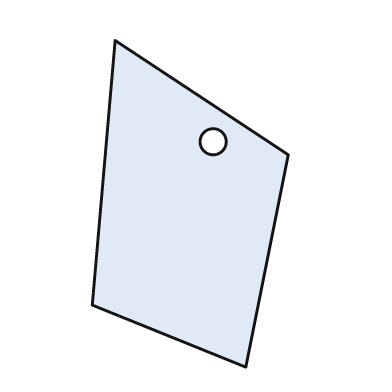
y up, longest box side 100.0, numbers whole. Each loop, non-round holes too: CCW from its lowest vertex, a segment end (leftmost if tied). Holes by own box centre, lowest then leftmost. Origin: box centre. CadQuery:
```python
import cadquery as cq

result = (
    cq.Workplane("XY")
    .moveTo(17.0, -50.0)
    .lineTo(30.0, 15.0)
    .lineTo(-23.0, 50.0)
    .lineTo(-30.0, -31.0)
    .close()
    .moveTo(7.0, 19.0)
    .circle(4.0)
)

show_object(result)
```